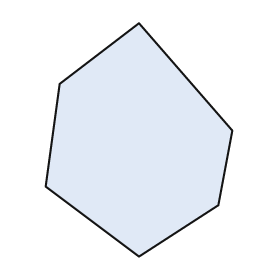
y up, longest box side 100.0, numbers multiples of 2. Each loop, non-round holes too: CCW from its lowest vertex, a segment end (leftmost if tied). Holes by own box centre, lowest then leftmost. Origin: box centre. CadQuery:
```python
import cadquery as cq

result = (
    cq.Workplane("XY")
    .moveTo(0.0, -50.0)
    .lineTo(34.0, -28.0)
    .lineTo(40.0, 4.0)
    .lineTo(0.0, 50.0)
    .lineTo(-34.0, 24.0)
    .lineTo(-40.0, -20.0)
    .close()
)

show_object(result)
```